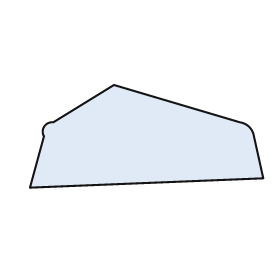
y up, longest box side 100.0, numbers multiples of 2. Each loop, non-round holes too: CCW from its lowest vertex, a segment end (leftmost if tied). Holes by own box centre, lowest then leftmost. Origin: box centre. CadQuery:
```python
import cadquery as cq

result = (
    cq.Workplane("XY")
    .moveTo(-50.0, -22.0)
    .lineTo(50.0, -18.0)
    .lineTo(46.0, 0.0)
    .threePointArc((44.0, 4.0), (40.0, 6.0))
    .lineTo(-14.0, 22.0)
    .lineTo(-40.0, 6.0)
    .threePointArc((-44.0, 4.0), (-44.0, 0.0))
    .close()
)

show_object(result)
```